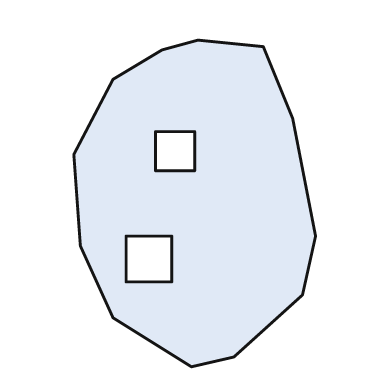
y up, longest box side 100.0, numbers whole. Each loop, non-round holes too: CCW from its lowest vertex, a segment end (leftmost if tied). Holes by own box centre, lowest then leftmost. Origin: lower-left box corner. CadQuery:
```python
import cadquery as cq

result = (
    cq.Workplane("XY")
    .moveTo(36.0, 0.0)
    .lineTo(49.0, 3.0)
    .lineTo(70.0, 22.0)
    .lineTo(74.0, 40.0)
    .lineTo(67.0, 76.0)
    .lineTo(58.0, 98.0)
    .lineTo(38.0, 100.0)
    .lineTo(27.0, 97.0)
    .lineTo(12.0, 88.0)
    .lineTo(0.0, 65.0)
    .lineTo(2.0, 37.0)
    .lineTo(12.0, 15.0)
    .close()
    .moveTo(16.0, 26.0)
    .lineTo(30.0, 26.0)
    .lineTo(30.0, 40.0)
    .lineTo(16.0, 40.0)
    .close()
    .moveTo(25.0, 60.0)
    .lineTo(37.0, 60.0)
    .lineTo(37.0, 72.0)
    .lineTo(25.0, 72.0)
    .close()
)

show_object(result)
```